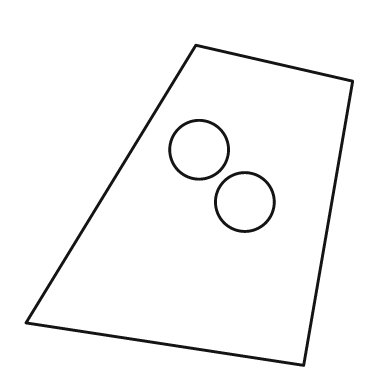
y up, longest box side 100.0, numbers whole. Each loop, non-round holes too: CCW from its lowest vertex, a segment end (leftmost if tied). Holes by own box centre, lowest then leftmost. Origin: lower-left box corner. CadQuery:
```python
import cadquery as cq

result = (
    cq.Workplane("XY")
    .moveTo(85.0, 0.0)
    .lineTo(100.0, 87.0)
    .lineTo(52.0, 98.0)
    .lineTo(0.0, 13.0)
    .close()
    .moveTo(67.0, 50.0)
    .circle(9.0)
    .moveTo(53.0, 66.0)
    .circle(9.0)
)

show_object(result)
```